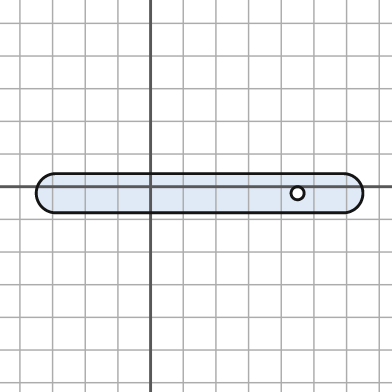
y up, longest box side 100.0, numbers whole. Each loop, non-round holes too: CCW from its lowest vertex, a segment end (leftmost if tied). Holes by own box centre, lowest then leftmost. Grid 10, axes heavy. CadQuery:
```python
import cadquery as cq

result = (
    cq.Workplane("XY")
    .moveTo(-29.0, -8.0)
    .lineTo(59.0, -8.0)
    .threePointArc((65.0, -2.0), (59.0, 4.0))
    .lineTo(-29.0, 4.0)
    .threePointArc((-35.0, -2.0), (-29.0, -8.0))
    .close()
    .moveTo(45.0, -2.0)
    .circle(2.0)
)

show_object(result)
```